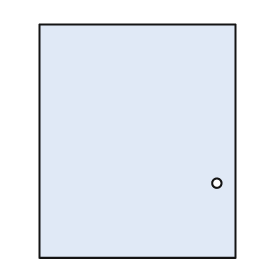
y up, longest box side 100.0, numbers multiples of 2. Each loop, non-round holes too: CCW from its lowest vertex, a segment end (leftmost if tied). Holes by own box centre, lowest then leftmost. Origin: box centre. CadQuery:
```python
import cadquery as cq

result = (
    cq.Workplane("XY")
    .moveTo(-42.0, -50.0)
    .lineTo(42.0, -50.0)
    .lineTo(42.0, 50.0)
    .lineTo(-42.0, 50.0)
    .close()
    .moveTo(34.0, -18.0)
    .circle(2.0)
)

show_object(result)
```